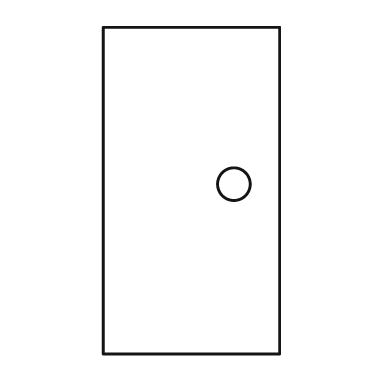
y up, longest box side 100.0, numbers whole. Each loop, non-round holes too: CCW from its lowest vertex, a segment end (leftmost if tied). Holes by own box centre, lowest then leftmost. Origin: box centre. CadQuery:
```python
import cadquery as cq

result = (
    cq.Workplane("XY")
    .moveTo(-27.0, -50.0)
    .lineTo(27.0, -50.0)
    .lineTo(27.0, 50.0)
    .lineTo(-27.0, 50.0)
    .close()
    .moveTo(13.0, 2.0)
    .circle(5.0)
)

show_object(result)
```